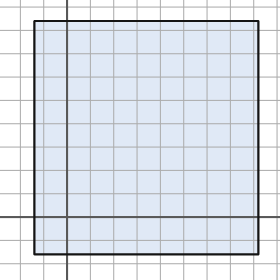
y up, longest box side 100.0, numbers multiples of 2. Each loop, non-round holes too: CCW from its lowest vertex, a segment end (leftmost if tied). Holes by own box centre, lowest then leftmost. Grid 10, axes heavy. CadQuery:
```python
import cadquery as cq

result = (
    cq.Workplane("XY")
    .moveTo(-14.0, -16.0)
    .lineTo(82.0, -16.0)
    .lineTo(82.0, 84.0)
    .lineTo(-14.0, 84.0)
    .close()
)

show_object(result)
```